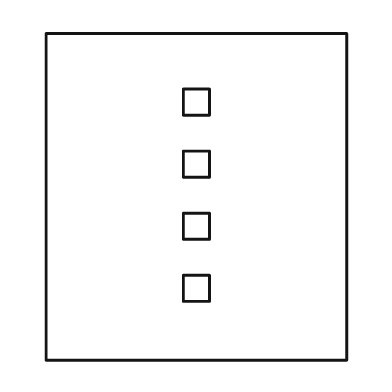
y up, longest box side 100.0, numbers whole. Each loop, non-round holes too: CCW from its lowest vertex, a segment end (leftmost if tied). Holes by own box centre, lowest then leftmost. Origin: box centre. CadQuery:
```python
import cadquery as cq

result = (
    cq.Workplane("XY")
    .moveTo(-46.0, -50.0)
    .lineTo(46.0, -50.0)
    .lineTo(46.0, 50.0)
    .lineTo(-46.0, 50.0)
    .close()
    .moveTo(-4.0, -32.0)
    .lineTo(4.0, -32.0)
    .lineTo(4.0, -24.0)
    .lineTo(-4.0, -24.0)
    .close()
    .moveTo(-4.0, -13.0)
    .lineTo(4.0, -13.0)
    .lineTo(4.0, -5.0)
    .lineTo(-4.0, -5.0)
    .close()
    .moveTo(-4.0, 6.0)
    .lineTo(4.0, 6.0)
    .lineTo(4.0, 14.0)
    .lineTo(-4.0, 14.0)
    .close()
    .moveTo(-4.0, 25.0)
    .lineTo(4.0, 25.0)
    .lineTo(4.0, 33.0)
    .lineTo(-4.0, 33.0)
    .close()
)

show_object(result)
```